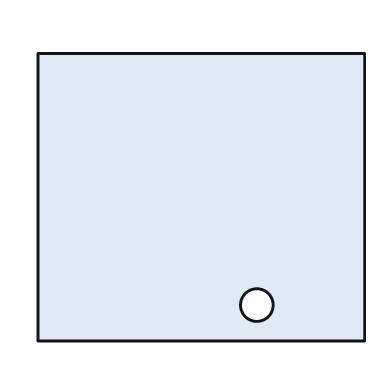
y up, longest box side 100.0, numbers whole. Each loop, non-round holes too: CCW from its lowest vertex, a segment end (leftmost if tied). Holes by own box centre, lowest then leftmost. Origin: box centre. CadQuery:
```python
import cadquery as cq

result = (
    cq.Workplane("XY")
    .moveTo(-50.0, -44.0)
    .lineTo(50.0, -44.0)
    .lineTo(50.0, 44.0)
    .lineTo(-50.0, 44.0)
    .close()
    .moveTo(17.0, -33.0)
    .circle(5.0)
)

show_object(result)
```